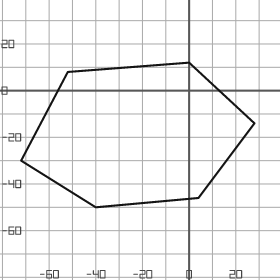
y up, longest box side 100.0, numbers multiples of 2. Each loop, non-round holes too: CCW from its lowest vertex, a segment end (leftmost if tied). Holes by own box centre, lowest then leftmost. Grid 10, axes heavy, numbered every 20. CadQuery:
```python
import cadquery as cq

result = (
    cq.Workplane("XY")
    .moveTo(-40.0, -50.0)
    .lineTo(4.0, -46.0)
    .lineTo(28.0, -14.0)
    .lineTo(0.0, 12.0)
    .lineTo(-52.0, 8.0)
    .lineTo(-72.0, -30.0)
    .close()
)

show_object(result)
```